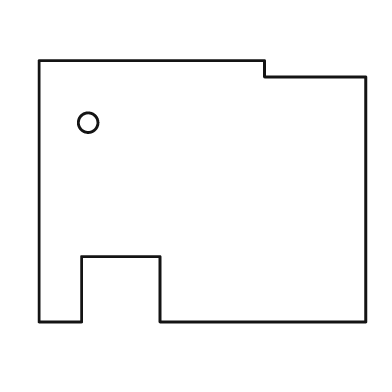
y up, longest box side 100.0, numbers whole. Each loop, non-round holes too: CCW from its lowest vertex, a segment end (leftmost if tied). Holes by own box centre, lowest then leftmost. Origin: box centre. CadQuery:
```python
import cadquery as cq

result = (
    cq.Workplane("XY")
    .moveTo(-50.0, -40.0)
    .lineTo(-37.0, -40.0)
    .lineTo(-37.0, -20.0)
    .lineTo(-13.0, -20.0)
    .lineTo(-13.0, -40.0)
    .lineTo(50.0, -40.0)
    .lineTo(50.0, 35.0)
    .lineTo(19.0, 35.0)
    .lineTo(19.0, 40.0)
    .lineTo(-50.0, 40.0)
    .close()
    .moveTo(-35.0, 21.0)
    .circle(3.0)
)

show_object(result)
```